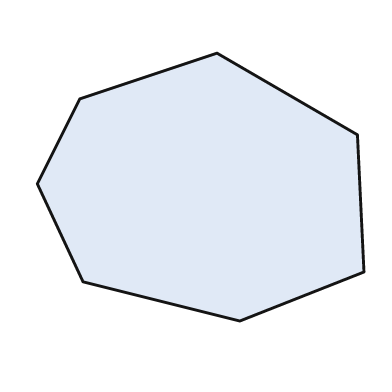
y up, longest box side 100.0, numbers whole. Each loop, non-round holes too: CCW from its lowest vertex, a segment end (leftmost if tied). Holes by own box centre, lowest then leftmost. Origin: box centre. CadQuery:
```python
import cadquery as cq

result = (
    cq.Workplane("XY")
    .moveTo(12.0, -41.0)
    .lineTo(50.0, -26.0)
    .lineTo(48.0, 16.0)
    .lineTo(5.0, 41.0)
    .lineTo(-37.0, 27.0)
    .lineTo(-50.0, 1.0)
    .lineTo(-36.0, -29.0)
    .close()
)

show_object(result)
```